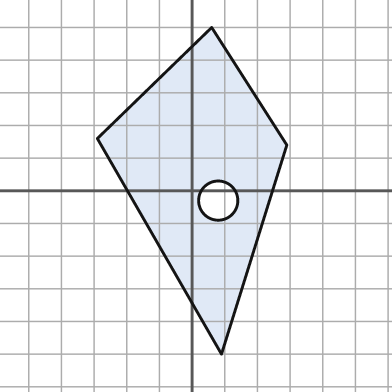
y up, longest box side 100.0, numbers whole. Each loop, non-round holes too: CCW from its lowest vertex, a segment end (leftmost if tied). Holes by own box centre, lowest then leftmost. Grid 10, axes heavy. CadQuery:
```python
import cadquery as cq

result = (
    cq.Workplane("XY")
    .moveTo(9.0, -50.0)
    .lineTo(29.0, 14.0)
    .lineTo(6.0, 50.0)
    .lineTo(-29.0, 16.0)
    .close()
    .moveTo(8.0, -3.0)
    .circle(6.0)
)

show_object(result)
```